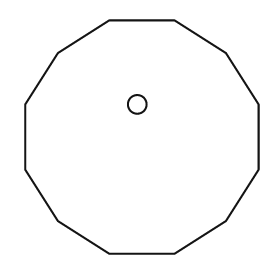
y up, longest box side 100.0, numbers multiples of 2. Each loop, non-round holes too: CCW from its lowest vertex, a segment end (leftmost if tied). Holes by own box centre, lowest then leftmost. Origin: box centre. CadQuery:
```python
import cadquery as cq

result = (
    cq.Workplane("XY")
    .moveTo(-14.0, -50.0)
    .lineTo(14.0, -50.0)
    .lineTo(36.0, -36.0)
    .lineTo(50.0, -14.0)
    .lineTo(50.0, 14.0)
    .lineTo(36.0, 36.0)
    .lineTo(14.0, 50.0)
    .lineTo(-14.0, 50.0)
    .lineTo(-36.0, 36.0)
    .lineTo(-50.0, 14.0)
    .lineTo(-50.0, -14.0)
    .lineTo(-36.0, -36.0)
    .close()
    .moveTo(-2.0, 14.0)
    .circle(4.0)
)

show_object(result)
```